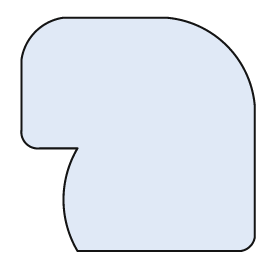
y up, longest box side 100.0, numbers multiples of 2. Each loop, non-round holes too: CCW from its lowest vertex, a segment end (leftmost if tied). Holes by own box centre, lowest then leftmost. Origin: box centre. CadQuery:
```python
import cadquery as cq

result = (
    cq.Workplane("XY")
    .moveTo(-26.0, -50.0)
    .lineTo(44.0, -50.0)
    .threePointArc((48.0, -48.0), (50.0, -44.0))
    .lineTo(50.0, 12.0)
    .threePointArc((38.0, 38.0), (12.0, 50.0))
    .lineTo(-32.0, 50.0)
    .threePointArc((-44.0, 44.0), (-50.0, 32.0))
    .lineTo(-50.0, 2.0)
    .threePointArc((-48.0, -4.0), (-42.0, -6.0))
    .lineTo(-26.0, -6.0)
    .threePointArc((-32.0, -28.0), (-26.0, -50.0))
    .close()
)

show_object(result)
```